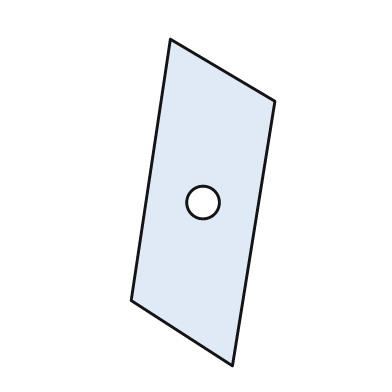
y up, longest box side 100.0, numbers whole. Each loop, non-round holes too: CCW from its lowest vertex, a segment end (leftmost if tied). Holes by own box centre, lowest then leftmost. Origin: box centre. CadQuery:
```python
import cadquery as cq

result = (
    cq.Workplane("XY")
    .moveTo(9.0, -50.0)
    .lineTo(22.0, 31.0)
    .lineTo(-10.0, 50.0)
    .lineTo(-22.0, -30.0)
    .close()
    .moveTo(0.0, 0.0)
    .circle(5.0)
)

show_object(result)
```